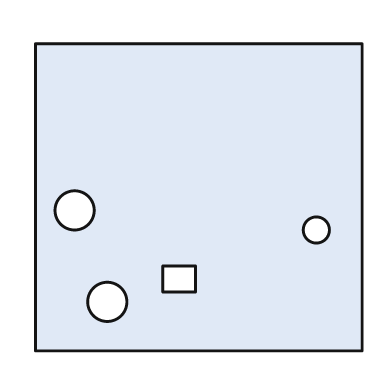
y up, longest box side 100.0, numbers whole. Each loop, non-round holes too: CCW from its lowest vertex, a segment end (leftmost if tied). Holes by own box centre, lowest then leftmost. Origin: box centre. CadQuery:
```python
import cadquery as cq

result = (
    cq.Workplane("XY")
    .moveTo(-50.0, -47.0)
    .lineTo(50.0, -47.0)
    .lineTo(50.0, 47.0)
    .lineTo(-50.0, 47.0)
    .close()
    .moveTo(-28.0, -32.0)
    .circle(6.0)
    .moveTo(-11.0, -29.0)
    .lineTo(-1.0, -29.0)
    .lineTo(-1.0, -21.0)
    .lineTo(-11.0, -21.0)
    .close()
    .moveTo(36.0, -10.0)
    .circle(4.0)
    .moveTo(-38.0, -4.0)
    .circle(6.0)
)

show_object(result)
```